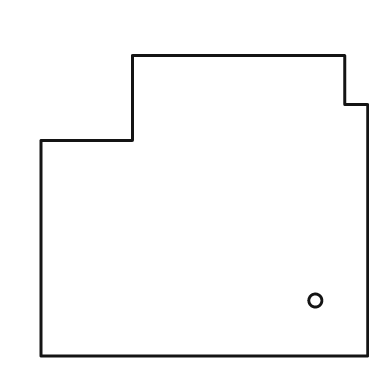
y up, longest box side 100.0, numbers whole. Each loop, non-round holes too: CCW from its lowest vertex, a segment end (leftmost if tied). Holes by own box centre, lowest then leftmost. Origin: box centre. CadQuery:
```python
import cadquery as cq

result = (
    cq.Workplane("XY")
    .moveTo(-50.0, -46.0)
    .lineTo(50.0, -46.0)
    .lineTo(50.0, 31.0)
    .lineTo(43.0, 31.0)
    .lineTo(43.0, 46.0)
    .lineTo(-22.0, 46.0)
    .lineTo(-22.0, 20.0)
    .lineTo(-50.0, 20.0)
    .close()
    .moveTo(34.0, -29.0)
    .circle(2.0)
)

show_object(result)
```